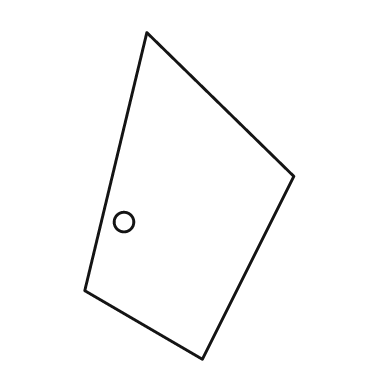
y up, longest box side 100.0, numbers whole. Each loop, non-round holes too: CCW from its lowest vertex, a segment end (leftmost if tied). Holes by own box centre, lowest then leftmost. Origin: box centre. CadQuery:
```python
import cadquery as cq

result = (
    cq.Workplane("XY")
    .moveTo(4.0, -50.0)
    .lineTo(32.0, 6.0)
    .lineTo(-13.0, 50.0)
    .lineTo(-32.0, -29.0)
    .close()
    .moveTo(-20.0, -8.0)
    .circle(3.0)
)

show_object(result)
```